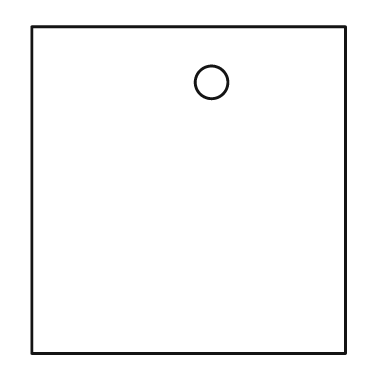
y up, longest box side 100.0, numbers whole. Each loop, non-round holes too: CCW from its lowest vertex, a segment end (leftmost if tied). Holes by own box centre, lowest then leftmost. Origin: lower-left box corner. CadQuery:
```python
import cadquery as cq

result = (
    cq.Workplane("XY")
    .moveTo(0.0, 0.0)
    .lineTo(96.0, 0.0)
    .lineTo(96.0, 100.0)
    .lineTo(0.0, 100.0)
    .close()
    .moveTo(55.0, 83.0)
    .circle(5.0)
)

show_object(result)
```